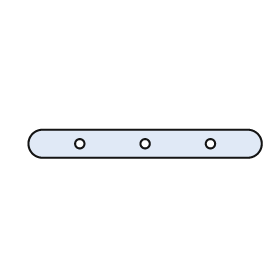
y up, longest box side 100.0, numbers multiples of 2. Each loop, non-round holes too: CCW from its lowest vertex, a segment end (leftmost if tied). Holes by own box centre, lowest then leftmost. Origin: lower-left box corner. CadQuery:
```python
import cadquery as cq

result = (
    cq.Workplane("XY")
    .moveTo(6.0, 0.0)
    .lineTo(94.0, 0.0)
    .threePointArc((100.0, 6.0), (94.0, 12.0))
    .lineTo(6.0, 12.0)
    .threePointArc((0.0, 6.0), (6.0, 0.0))
    .close()
    .moveTo(22.0, 6.0)
    .circle(2.0)
    .moveTo(50.0, 6.0)
    .circle(2.0)
    .moveTo(78.0, 6.0)
    .circle(2.0)
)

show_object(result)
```